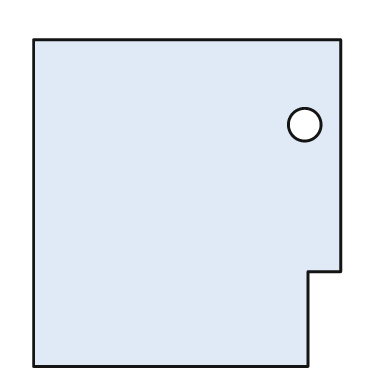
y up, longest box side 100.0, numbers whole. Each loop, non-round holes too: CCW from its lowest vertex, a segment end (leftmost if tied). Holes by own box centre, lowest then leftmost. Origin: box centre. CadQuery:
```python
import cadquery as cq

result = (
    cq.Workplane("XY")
    .moveTo(-47.0, -50.0)
    .lineTo(37.0, -50.0)
    .lineTo(37.0, -21.0)
    .lineTo(47.0, -21.0)
    .lineTo(47.0, 50.0)
    .lineTo(-47.0, 50.0)
    .close()
    .moveTo(36.0, 24.0)
    .circle(5.0)
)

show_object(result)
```